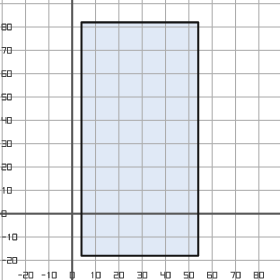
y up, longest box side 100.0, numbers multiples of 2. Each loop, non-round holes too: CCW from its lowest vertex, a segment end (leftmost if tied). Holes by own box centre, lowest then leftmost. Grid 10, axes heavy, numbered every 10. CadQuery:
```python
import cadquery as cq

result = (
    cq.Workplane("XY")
    .moveTo(4.0, -18.0)
    .lineTo(54.0, -18.0)
    .lineTo(54.0, 82.0)
    .lineTo(4.0, 82.0)
    .close()
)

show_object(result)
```